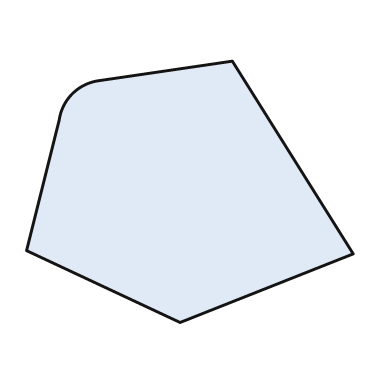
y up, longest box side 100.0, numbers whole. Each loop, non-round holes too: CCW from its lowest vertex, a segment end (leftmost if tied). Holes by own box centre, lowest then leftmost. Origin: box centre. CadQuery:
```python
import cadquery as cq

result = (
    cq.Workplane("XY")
    .moveTo(-3.0, -40.0)
    .lineTo(50.0, -19.0)
    .lineTo(13.0, 40.0)
    .lineTo(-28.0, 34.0)
    .threePointArc((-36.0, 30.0), (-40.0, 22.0))
    .lineTo(-50.0, -18.0)
    .close()
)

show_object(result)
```